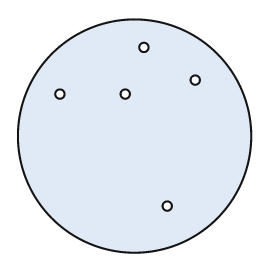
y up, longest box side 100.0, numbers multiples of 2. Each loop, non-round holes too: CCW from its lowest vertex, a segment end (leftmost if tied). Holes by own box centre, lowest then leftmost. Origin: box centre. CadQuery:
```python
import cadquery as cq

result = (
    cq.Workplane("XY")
    .moveTo(0.0, 0.0)
    .circle(50.0)
    .moveTo(14.0, -30.0)
    .circle(2.0)
    .moveTo(-32.0, 18.0)
    .circle(2.0)
    .moveTo(-4.0, 18.0)
    .circle(2.0)
    .moveTo(26.0, 24.0)
    .circle(2.0)
    .moveTo(4.0, 38.0)
    .circle(2.0)
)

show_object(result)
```